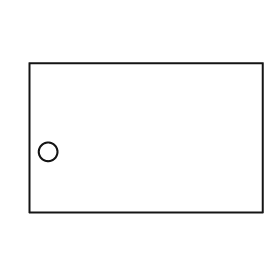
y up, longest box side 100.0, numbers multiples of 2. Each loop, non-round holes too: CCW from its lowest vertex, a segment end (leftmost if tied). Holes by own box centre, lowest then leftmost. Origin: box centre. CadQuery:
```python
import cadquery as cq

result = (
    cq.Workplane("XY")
    .moveTo(-50.0, -32.0)
    .lineTo(50.0, -32.0)
    .lineTo(50.0, 32.0)
    .lineTo(-50.0, 32.0)
    .close()
    .moveTo(-42.0, -6.0)
    .circle(4.0)
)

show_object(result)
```